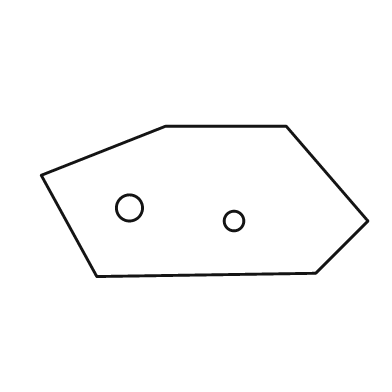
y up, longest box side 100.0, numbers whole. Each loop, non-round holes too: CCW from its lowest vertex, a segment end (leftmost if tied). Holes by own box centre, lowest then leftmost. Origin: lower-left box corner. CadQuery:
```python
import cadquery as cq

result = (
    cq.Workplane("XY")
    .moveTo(17.0, 0.0)
    .lineTo(84.0, 1.0)
    .lineTo(100.0, 17.0)
    .lineTo(75.0, 46.0)
    .lineTo(38.0, 46.0)
    .lineTo(0.0, 31.0)
    .close()
    .moveTo(59.0, 17.0)
    .circle(3.0)
    .moveTo(27.0, 21.0)
    .circle(4.0)
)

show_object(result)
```